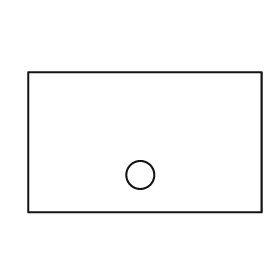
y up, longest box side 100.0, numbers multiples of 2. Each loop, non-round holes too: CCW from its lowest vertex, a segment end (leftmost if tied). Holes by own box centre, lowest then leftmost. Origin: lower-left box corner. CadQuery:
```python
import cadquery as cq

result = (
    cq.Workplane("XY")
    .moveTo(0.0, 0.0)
    .lineTo(100.0, 0.0)
    .lineTo(100.0, 60.0)
    .lineTo(0.0, 60.0)
    .close()
    .moveTo(48.0, 16.0)
    .circle(6.0)
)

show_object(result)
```